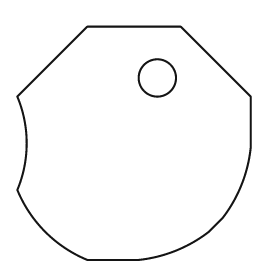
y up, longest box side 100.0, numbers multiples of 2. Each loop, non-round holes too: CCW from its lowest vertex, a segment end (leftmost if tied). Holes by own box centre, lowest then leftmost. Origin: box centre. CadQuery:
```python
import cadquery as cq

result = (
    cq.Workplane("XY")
    .moveTo(-20.0, -50.0)
    .lineTo(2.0, -50.0)
    .threePointArc((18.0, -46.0), (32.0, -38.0))
    .lineTo(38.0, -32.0)
    .threePointArc((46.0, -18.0), (50.0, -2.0))
    .lineTo(50.0, 20.0)
    .lineTo(20.0, 50.0)
    .lineTo(-20.0, 50.0)
    .lineTo(-50.0, 20.0)
    .threePointArc((-46.0, 0.0), (-50.0, -20.0))
    .threePointArc((-38.0, -38.0), (-20.0, -50.0))
    .close()
    .moveTo(10.0, 28.0)
    .circle(8.0)
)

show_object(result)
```